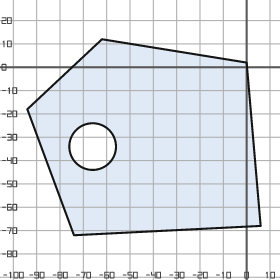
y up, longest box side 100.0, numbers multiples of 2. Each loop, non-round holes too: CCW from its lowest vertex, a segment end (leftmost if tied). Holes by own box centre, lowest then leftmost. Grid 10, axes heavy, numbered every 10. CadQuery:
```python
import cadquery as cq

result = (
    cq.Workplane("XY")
    .moveTo(-74.0, -72.0)
    .lineTo(6.0, -68.0)
    .lineTo(0.0, 2.0)
    .lineTo(-62.0, 12.0)
    .lineTo(-94.0, -18.0)
    .close()
    .moveTo(-66.0, -34.0)
    .circle(10.0)
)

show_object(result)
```